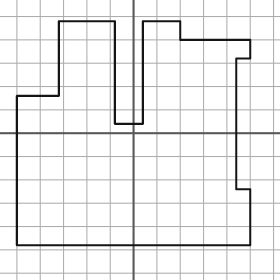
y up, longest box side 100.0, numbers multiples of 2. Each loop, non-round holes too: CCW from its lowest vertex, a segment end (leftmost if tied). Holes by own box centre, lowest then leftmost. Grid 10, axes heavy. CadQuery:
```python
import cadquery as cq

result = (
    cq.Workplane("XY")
    .moveTo(-50.0, -48.0)
    .lineTo(50.0, -48.0)
    .lineTo(50.0, -24.0)
    .lineTo(44.0, -24.0)
    .lineTo(44.0, 32.0)
    .lineTo(50.0, 32.0)
    .lineTo(50.0, 40.0)
    .lineTo(20.0, 40.0)
    .lineTo(20.0, 48.0)
    .lineTo(4.0, 48.0)
    .lineTo(4.0, 4.0)
    .lineTo(-8.0, 4.0)
    .lineTo(-8.0, 48.0)
    .lineTo(-32.0, 48.0)
    .lineTo(-32.0, 16.0)
    .lineTo(-50.0, 16.0)
    .close()
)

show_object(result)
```